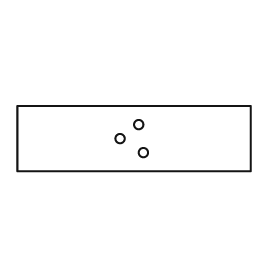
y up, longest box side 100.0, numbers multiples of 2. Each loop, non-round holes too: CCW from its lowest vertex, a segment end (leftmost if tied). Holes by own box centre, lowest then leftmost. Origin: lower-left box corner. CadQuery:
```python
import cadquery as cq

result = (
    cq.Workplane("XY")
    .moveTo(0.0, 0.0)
    .lineTo(100.0, 0.0)
    .lineTo(100.0, 28.0)
    .lineTo(0.0, 28.0)
    .close()
    .moveTo(54.0, 8.0)
    .circle(2.0)
    .moveTo(44.0, 14.0)
    .circle(2.0)
    .moveTo(52.0, 20.0)
    .circle(2.0)
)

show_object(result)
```